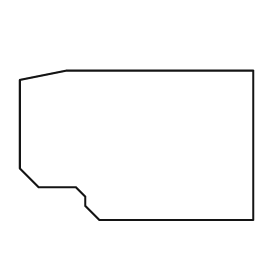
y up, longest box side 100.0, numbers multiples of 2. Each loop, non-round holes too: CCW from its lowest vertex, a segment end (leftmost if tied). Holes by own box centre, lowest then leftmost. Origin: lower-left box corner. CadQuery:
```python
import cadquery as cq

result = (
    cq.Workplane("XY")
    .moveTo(34.0, 0.0)
    .lineTo(100.0, 0.0)
    .lineTo(100.0, 64.0)
    .lineTo(20.0, 64.0)
    .lineTo(0.0, 60.0)
    .lineTo(0.0, 22.0)
    .lineTo(8.0, 14.0)
    .lineTo(24.0, 14.0)
    .lineTo(28.0, 10.0)
    .lineTo(28.0, 6.0)
    .close()
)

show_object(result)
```